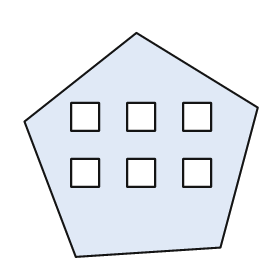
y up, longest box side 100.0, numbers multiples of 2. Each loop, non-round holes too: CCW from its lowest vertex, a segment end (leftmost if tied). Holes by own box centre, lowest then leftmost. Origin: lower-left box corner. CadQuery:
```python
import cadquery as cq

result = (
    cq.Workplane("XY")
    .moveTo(22.0, 0.0)
    .lineTo(84.0, 4.0)
    .lineTo(100.0, 64.0)
    .lineTo(48.0, 96.0)
    .lineTo(0.0, 58.0)
    .close()
    .moveTo(20.0, 30.0)
    .lineTo(32.0, 30.0)
    .lineTo(32.0, 42.0)
    .lineTo(20.0, 42.0)
    .close()
    .moveTo(44.0, 30.0)
    .lineTo(56.0, 30.0)
    .lineTo(56.0, 42.0)
    .lineTo(44.0, 42.0)
    .close()
    .moveTo(68.0, 30.0)
    .lineTo(80.0, 30.0)
    .lineTo(80.0, 42.0)
    .lineTo(68.0, 42.0)
    .close()
    .moveTo(20.0, 54.0)
    .lineTo(32.0, 54.0)
    .lineTo(32.0, 66.0)
    .lineTo(20.0, 66.0)
    .close()
    .moveTo(44.0, 54.0)
    .lineTo(56.0, 54.0)
    .lineTo(56.0, 66.0)
    .lineTo(44.0, 66.0)
    .close()
    .moveTo(68.0, 54.0)
    .lineTo(80.0, 54.0)
    .lineTo(80.0, 66.0)
    .lineTo(68.0, 66.0)
    .close()
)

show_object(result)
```